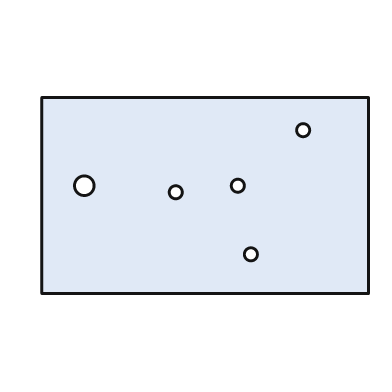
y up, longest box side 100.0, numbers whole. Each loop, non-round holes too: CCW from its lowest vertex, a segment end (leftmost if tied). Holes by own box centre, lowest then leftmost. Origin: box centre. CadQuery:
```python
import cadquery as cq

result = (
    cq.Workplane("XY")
    .moveTo(-50.0, -30.0)
    .lineTo(50.0, -30.0)
    .lineTo(50.0, 30.0)
    .lineTo(-50.0, 30.0)
    .close()
    .moveTo(14.0, -18.0)
    .circle(2.0)
    .moveTo(-9.0, 1.0)
    .circle(2.0)
    .moveTo(-37.0, 3.0)
    .circle(3.0)
    .moveTo(10.0, 3.0)
    .circle(2.0)
    .moveTo(30.0, 20.0)
    .circle(2.0)
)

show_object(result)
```